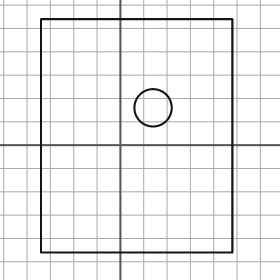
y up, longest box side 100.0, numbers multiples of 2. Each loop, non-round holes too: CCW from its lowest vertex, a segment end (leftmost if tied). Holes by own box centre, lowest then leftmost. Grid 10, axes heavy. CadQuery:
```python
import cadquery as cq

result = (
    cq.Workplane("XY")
    .moveTo(-34.0, -46.0)
    .lineTo(48.0, -46.0)
    .lineTo(48.0, 54.0)
    .lineTo(-34.0, 54.0)
    .close()
    .moveTo(14.0, 16.0)
    .circle(8.0)
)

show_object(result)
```